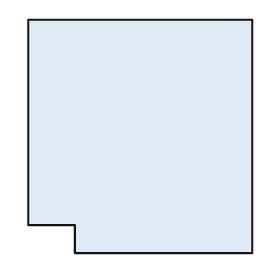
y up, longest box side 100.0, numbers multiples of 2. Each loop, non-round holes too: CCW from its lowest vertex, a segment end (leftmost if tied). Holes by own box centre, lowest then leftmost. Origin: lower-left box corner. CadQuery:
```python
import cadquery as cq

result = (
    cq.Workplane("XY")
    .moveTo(20.0, 0.0)
    .lineTo(96.0, 0.0)
    .lineTo(96.0, 100.0)
    .lineTo(0.0, 100.0)
    .lineTo(0.0, 12.0)
    .lineTo(20.0, 12.0)
    .close()
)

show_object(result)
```